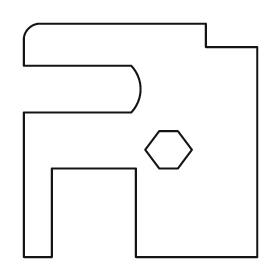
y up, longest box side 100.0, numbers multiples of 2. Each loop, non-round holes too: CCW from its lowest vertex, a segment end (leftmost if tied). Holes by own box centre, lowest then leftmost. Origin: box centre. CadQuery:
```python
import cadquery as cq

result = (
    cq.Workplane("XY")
    .moveTo(-50.0, -50.0)
    .lineTo(-38.0, -50.0)
    .lineTo(-38.0, -12.0)
    .lineTo(-2.0, -12.0)
    .lineTo(-2.0, -50.0)
    .lineTo(50.0, -50.0)
    .lineTo(50.0, 40.0)
    .lineTo(28.0, 40.0)
    .lineTo(28.0, 50.0)
    .lineTo(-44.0, 50.0)
    .threePointArc((-48.0, 48.0), (-50.0, 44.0))
    .lineTo(-50.0, 32.0)
    .lineTo(-4.0, 32.0)
    .threePointArc((0.0, 22.0), (-4.0, 12.0))
    .lineTo(-50.0, 12.0)
    .close()
    .moveTo(8.0, -12.0)
    .lineTo(16.0, -12.0)
    .lineTo(22.0, -4.0)
    .lineTo(16.0, 4.0)
    .lineTo(8.0, 4.0)
    .lineTo(2.0, -4.0)
    .close()
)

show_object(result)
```